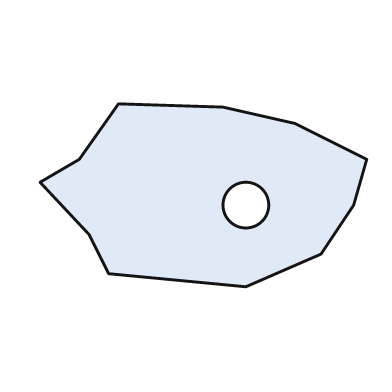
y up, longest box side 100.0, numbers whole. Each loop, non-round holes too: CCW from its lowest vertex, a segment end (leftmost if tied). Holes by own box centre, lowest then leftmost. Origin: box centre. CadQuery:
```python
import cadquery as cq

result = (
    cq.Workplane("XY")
    .moveTo(13.0, -28.0)
    .lineTo(36.0, -18.0)
    .lineTo(46.0, -3.0)
    .lineTo(50.0, 11.0)
    .lineTo(28.0, 22.0)
    .lineTo(6.0, 27.0)
    .lineTo(-26.0, 28.0)
    .lineTo(-38.0, 11.0)
    .lineTo(-50.0, 4.0)
    .lineTo(-35.0, -12.0)
    .lineTo(-29.0, -24.0)
    .close()
    .moveTo(13.0, -3.0)
    .circle(7.0)
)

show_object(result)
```